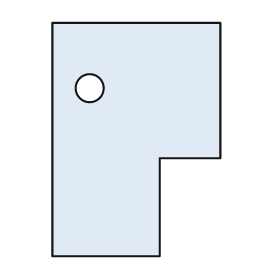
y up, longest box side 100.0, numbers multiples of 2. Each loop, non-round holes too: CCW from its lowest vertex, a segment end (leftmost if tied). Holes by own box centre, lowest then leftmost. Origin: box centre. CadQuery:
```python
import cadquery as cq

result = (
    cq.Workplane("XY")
    .moveTo(-36.0, -50.0)
    .lineTo(10.0, -50.0)
    .lineTo(10.0, -8.0)
    .lineTo(36.0, -8.0)
    .lineTo(36.0, 50.0)
    .lineTo(-36.0, 50.0)
    .close()
    .moveTo(-20.0, 22.0)
    .circle(6.0)
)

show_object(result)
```